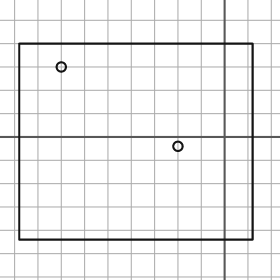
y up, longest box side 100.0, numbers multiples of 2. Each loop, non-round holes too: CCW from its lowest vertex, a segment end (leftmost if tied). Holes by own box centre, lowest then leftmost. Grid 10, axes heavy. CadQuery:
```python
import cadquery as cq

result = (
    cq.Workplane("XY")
    .moveTo(-88.0, -44.0)
    .lineTo(12.0, -44.0)
    .lineTo(12.0, 40.0)
    .lineTo(-88.0, 40.0)
    .close()
    .moveTo(-20.0, -4.0)
    .circle(2.0)
    .moveTo(-70.0, 30.0)
    .circle(2.0)
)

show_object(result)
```